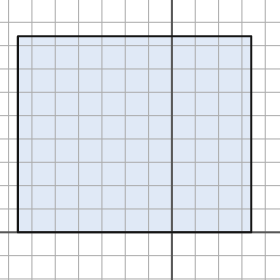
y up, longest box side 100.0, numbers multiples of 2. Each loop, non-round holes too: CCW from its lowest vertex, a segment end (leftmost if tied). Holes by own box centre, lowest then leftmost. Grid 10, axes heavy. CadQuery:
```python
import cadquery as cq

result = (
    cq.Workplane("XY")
    .moveTo(-66.0, 0.0)
    .lineTo(34.0, 0.0)
    .lineTo(34.0, 84.0)
    .lineTo(-66.0, 84.0)
    .close()
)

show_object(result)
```